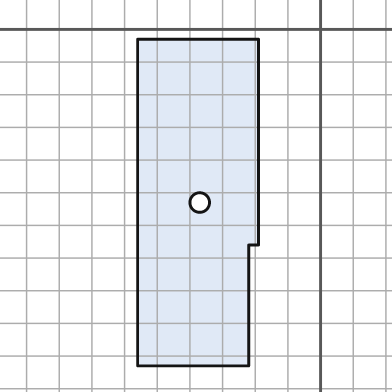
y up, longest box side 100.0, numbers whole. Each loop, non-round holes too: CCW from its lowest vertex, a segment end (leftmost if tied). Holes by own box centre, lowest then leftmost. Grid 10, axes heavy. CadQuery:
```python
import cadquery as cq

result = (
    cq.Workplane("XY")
    .moveTo(-56.0, -103.0)
    .lineTo(-22.0, -103.0)
    .lineTo(-22.0, -66.0)
    .lineTo(-19.0, -66.0)
    .lineTo(-19.0, -3.0)
    .lineTo(-56.0, -3.0)
    .close()
    .moveTo(-37.0, -53.0)
    .circle(3.0)
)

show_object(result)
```